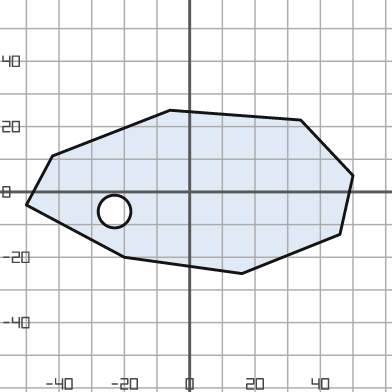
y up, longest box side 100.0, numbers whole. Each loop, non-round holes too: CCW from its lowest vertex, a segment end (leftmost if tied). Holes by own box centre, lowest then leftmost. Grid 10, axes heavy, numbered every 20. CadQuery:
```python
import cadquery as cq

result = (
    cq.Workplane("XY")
    .moveTo(16.0, -25.0)
    .lineTo(46.0, -13.0)
    .lineTo(50.0, 5.0)
    .lineTo(34.0, 22.0)
    .lineTo(-6.0, 25.0)
    .lineTo(-42.0, 11.0)
    .lineTo(-50.0, -4.0)
    .lineTo(-20.0, -20.0)
    .close()
    .moveTo(-23.0, -6.0)
    .circle(5.0)
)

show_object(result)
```